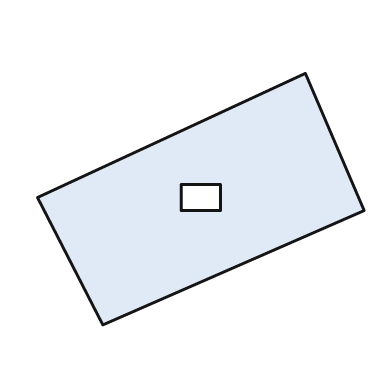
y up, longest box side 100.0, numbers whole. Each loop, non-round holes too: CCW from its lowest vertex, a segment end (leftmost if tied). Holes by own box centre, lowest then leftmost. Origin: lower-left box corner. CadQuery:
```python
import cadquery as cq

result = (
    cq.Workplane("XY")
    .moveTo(20.0, 0.0)
    .lineTo(100.0, 35.0)
    .lineTo(82.0, 77.0)
    .lineTo(0.0, 39.0)
    .close()
    .moveTo(44.0, 35.0)
    .lineTo(56.0, 35.0)
    .lineTo(56.0, 43.0)
    .lineTo(44.0, 43.0)
    .close()
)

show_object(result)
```